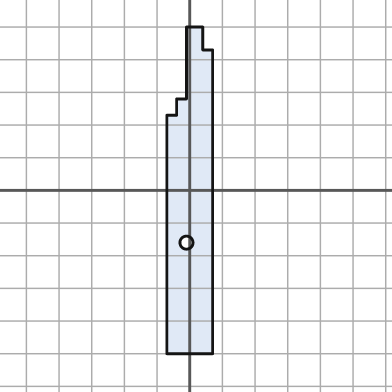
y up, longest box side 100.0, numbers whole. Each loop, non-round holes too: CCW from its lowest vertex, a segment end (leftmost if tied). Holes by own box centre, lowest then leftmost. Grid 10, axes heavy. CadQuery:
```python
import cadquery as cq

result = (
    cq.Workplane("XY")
    .moveTo(-7.0, -50.0)
    .lineTo(7.0, -50.0)
    .lineTo(7.0, 43.0)
    .lineTo(4.0, 43.0)
    .lineTo(4.0, 50.0)
    .lineTo(-1.0, 50.0)
    .lineTo(-1.0, 28.0)
    .lineTo(-4.0, 28.0)
    .lineTo(-4.0, 23.0)
    .lineTo(-7.0, 23.0)
    .close()
    .moveTo(-1.0, -16.0)
    .circle(2.0)
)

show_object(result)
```